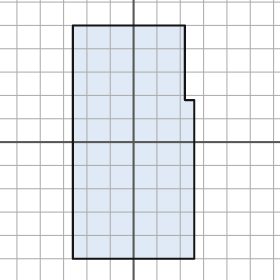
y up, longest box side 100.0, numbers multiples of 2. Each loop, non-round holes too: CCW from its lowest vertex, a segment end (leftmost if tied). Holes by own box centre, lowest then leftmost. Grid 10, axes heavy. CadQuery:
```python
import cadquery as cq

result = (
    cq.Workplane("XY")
    .moveTo(-26.0, -50.0)
    .lineTo(26.0, -50.0)
    .lineTo(26.0, 18.0)
    .lineTo(22.0, 18.0)
    .lineTo(22.0, 50.0)
    .lineTo(-26.0, 50.0)
    .close()
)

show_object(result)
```